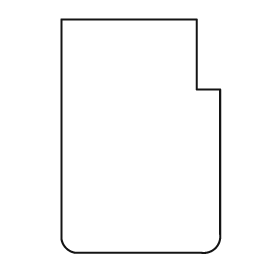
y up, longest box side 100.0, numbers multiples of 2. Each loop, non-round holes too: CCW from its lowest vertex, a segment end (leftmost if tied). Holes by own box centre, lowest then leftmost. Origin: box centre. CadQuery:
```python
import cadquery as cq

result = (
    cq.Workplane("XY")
    .moveTo(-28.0, -50.0)
    .lineTo(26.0, -50.0)
    .threePointArc((32.0, -48.0), (34.0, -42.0))
    .lineTo(34.0, 20.0)
    .lineTo(24.0, 20.0)
    .lineTo(24.0, 50.0)
    .lineTo(-34.0, 50.0)
    .lineTo(-34.0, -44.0)
    .threePointArc((-32.0, -48.0), (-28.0, -50.0))
    .close()
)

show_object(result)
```